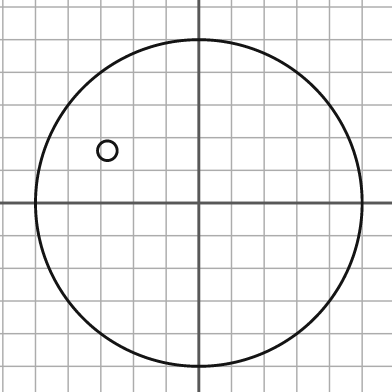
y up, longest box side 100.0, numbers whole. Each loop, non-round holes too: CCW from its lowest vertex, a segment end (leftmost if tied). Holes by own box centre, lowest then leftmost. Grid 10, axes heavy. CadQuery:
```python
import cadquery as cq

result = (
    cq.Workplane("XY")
    .moveTo(0.0, 0.0)
    .circle(50.0)
    .moveTo(-28.0, 16.0)
    .circle(3.0)
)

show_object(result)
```